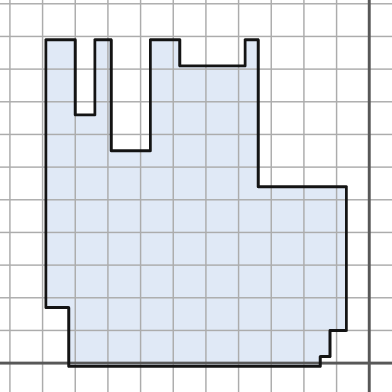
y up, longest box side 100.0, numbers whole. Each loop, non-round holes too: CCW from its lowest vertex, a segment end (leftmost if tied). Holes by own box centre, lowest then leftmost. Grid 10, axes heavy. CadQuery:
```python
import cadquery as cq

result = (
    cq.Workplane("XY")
    .moveTo(-92.0, -1.0)
    .lineTo(-15.0, -1.0)
    .lineTo(-15.0, 2.0)
    .lineTo(-12.0, 2.0)
    .lineTo(-12.0, 10.0)
    .lineTo(-7.0, 10.0)
    .lineTo(-7.0, 54.0)
    .lineTo(-34.0, 54.0)
    .lineTo(-34.0, 99.0)
    .lineTo(-38.0, 99.0)
    .lineTo(-38.0, 91.0)
    .lineTo(-58.0, 91.0)
    .lineTo(-58.0, 99.0)
    .lineTo(-67.0, 99.0)
    .lineTo(-67.0, 65.0)
    .lineTo(-79.0, 65.0)
    .lineTo(-79.0, 99.0)
    .lineTo(-84.0, 99.0)
    .lineTo(-84.0, 76.0)
    .lineTo(-90.0, 76.0)
    .lineTo(-90.0, 99.0)
    .lineTo(-99.0, 99.0)
    .lineTo(-99.0, 17.0)
    .lineTo(-92.0, 17.0)
    .close()
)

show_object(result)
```